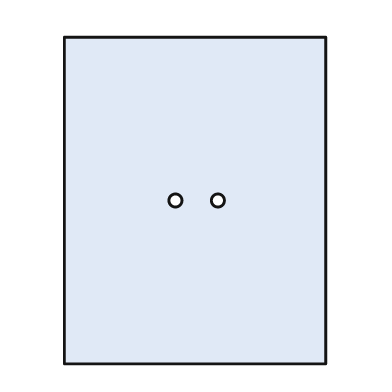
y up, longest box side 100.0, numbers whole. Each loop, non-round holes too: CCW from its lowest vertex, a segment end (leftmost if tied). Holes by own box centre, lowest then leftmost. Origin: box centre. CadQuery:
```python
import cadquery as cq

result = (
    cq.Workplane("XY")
    .moveTo(-40.0, -50.0)
    .lineTo(40.0, -50.0)
    .lineTo(40.0, 50.0)
    .lineTo(-40.0, 50.0)
    .close()
    .moveTo(-6.0, 0.0)
    .circle(2.0)
    .moveTo(7.0, 0.0)
    .circle(2.0)
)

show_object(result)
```